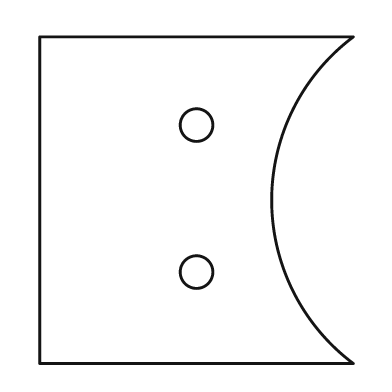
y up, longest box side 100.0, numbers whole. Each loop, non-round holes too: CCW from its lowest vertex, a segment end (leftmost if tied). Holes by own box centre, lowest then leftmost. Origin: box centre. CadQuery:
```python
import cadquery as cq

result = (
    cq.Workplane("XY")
    .moveTo(-48.0, -50.0)
    .lineTo(48.0, -50.0)
    .threePointArc((23.0, 0.0), (48.0, 50.0))
    .lineTo(-48.0, 50.0)
    .close()
    .moveTo(0.0, -22.0)
    .circle(5.0)
    .moveTo(0.0, 23.0)
    .circle(5.0)
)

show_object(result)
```